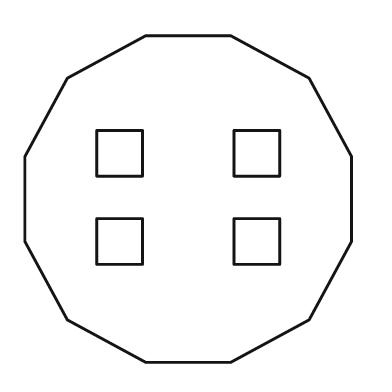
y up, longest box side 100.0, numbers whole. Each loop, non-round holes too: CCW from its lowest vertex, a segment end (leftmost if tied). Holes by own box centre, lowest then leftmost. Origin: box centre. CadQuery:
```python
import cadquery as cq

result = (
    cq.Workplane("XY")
    .moveTo(-13.0, -50.0)
    .lineTo(13.0, -50.0)
    .lineTo(37.0, -37.0)
    .lineTo(50.0, -13.0)
    .lineTo(50.0, 13.0)
    .lineTo(37.0, 37.0)
    .lineTo(13.0, 50.0)
    .lineTo(-13.0, 50.0)
    .lineTo(-37.0, 37.0)
    .lineTo(-50.0, 13.0)
    .lineTo(-50.0, -13.0)
    .lineTo(-37.0, -37.0)
    .close()
    .moveTo(-28.0, -20.0)
    .lineTo(-14.0, -20.0)
    .lineTo(-14.0, -6.0)
    .lineTo(-28.0, -6.0)
    .close()
    .moveTo(14.0, -20.0)
    .lineTo(28.0, -20.0)
    .lineTo(28.0, -6.0)
    .lineTo(14.0, -6.0)
    .close()
    .moveTo(-28.0, 7.0)
    .lineTo(-14.0, 7.0)
    .lineTo(-14.0, 21.0)
    .lineTo(-28.0, 21.0)
    .close()
    .moveTo(14.0, 7.0)
    .lineTo(28.0, 7.0)
    .lineTo(28.0, 21.0)
    .lineTo(14.0, 21.0)
    .close()
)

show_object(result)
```